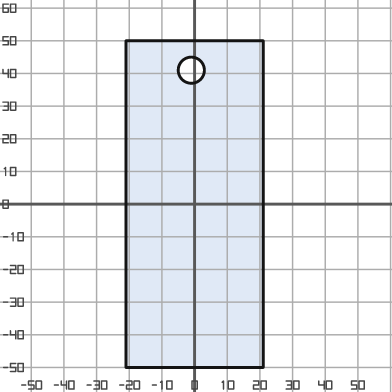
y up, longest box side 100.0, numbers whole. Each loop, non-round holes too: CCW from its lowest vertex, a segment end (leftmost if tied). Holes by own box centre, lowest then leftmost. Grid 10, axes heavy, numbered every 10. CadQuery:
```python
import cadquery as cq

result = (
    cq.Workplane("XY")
    .moveTo(-21.0, -50.0)
    .lineTo(21.0, -50.0)
    .lineTo(21.0, 50.0)
    .lineTo(-21.0, 50.0)
    .close()
    .moveTo(-1.0, 41.0)
    .circle(4.0)
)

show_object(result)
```